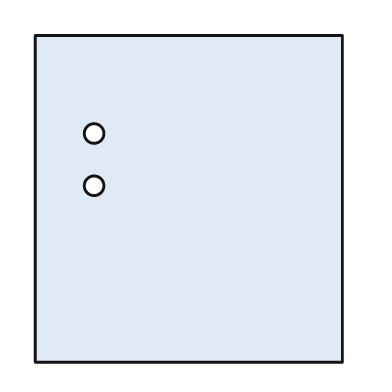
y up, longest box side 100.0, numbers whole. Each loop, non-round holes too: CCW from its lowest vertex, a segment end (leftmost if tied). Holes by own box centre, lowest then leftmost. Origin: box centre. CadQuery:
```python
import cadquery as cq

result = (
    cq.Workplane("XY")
    .moveTo(-47.0, -50.0)
    .lineTo(47.0, -50.0)
    .lineTo(47.0, 50.0)
    .lineTo(-47.0, 50.0)
    .close()
    .moveTo(-29.0, 4.0)
    .circle(3.0)
    .moveTo(-29.0, 20.0)
    .circle(3.0)
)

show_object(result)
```